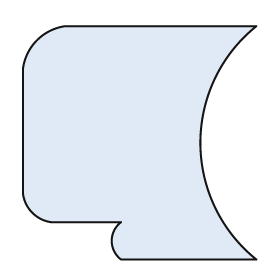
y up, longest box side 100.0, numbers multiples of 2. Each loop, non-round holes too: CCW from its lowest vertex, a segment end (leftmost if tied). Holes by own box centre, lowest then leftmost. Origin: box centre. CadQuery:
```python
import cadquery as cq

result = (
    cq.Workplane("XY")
    .moveTo(-8.0, -50.0)
    .lineTo(50.0, -50.0)
    .threePointArc((26.0, 0.0), (50.0, 50.0))
    .lineTo(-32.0, 50.0)
    .threePointArc((-44.0, 44.0), (-50.0, 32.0))
    .lineTo(-50.0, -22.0)
    .threePointArc((-46.0, -30.0), (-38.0, -34.0))
    .lineTo(-8.0, -34.0)
    .threePointArc((-12.0, -42.0), (-8.0, -50.0))
    .close()
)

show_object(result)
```